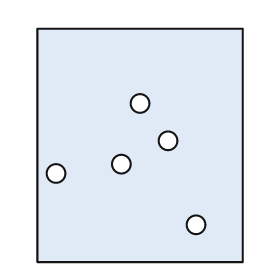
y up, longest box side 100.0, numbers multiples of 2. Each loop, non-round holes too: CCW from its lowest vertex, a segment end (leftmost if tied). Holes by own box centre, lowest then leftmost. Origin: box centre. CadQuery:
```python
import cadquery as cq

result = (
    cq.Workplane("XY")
    .moveTo(-44.0, -50.0)
    .lineTo(44.0, -50.0)
    .lineTo(44.0, 50.0)
    .lineTo(-44.0, 50.0)
    .close()
    .moveTo(24.0, -34.0)
    .circle(4.0)
    .moveTo(-36.0, -12.0)
    .circle(4.0)
    .moveTo(-8.0, -8.0)
    .circle(4.0)
    .moveTo(12.0, 2.0)
    .circle(4.0)
    .moveTo(0.0, 18.0)
    .circle(4.0)
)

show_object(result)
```